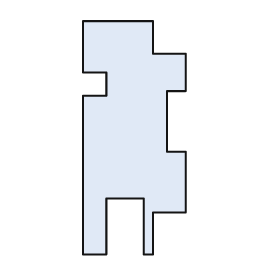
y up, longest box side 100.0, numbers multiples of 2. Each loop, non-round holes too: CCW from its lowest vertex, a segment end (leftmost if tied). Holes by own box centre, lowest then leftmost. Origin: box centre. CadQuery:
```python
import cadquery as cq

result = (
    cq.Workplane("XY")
    .moveTo(-22.0, -50.0)
    .lineTo(-12.0, -50.0)
    .lineTo(-12.0, -26.0)
    .lineTo(4.0, -26.0)
    .lineTo(4.0, -50.0)
    .lineTo(8.0, -50.0)
    .lineTo(8.0, -32.0)
    .lineTo(22.0, -32.0)
    .lineTo(22.0, -6.0)
    .lineTo(14.0, -6.0)
    .lineTo(14.0, 20.0)
    .lineTo(22.0, 20.0)
    .lineTo(22.0, 36.0)
    .lineTo(8.0, 36.0)
    .lineTo(8.0, 50.0)
    .lineTo(-22.0, 50.0)
    .lineTo(-22.0, 28.0)
    .lineTo(-12.0, 28.0)
    .lineTo(-12.0, 18.0)
    .lineTo(-22.0, 18.0)
    .close()
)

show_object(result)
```